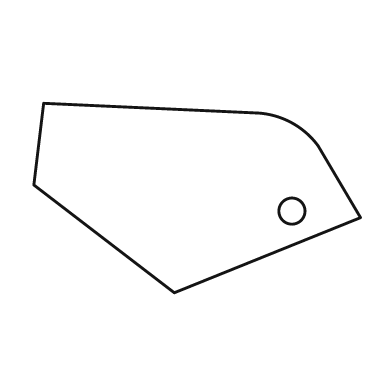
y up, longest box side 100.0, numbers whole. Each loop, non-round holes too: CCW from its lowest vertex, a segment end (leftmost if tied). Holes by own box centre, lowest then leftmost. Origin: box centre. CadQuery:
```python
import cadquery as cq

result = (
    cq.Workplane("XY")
    .moveTo(-7.0, -29.0)
    .lineTo(50.0, -6.0)
    .lineTo(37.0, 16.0)
    .threePointArc((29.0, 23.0), (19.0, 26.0))
    .lineTo(-47.0, 29.0)
    .lineTo(-50.0, 4.0)
    .close()
    .moveTo(29.0, -4.0)
    .circle(4.0)
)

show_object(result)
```